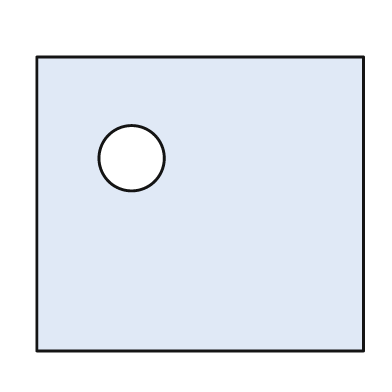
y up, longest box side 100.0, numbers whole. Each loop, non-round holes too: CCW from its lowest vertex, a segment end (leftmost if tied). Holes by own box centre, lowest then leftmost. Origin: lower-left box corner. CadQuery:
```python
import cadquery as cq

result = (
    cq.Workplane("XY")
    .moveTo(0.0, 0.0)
    .lineTo(100.0, 0.0)
    .lineTo(100.0, 90.0)
    .lineTo(0.0, 90.0)
    .close()
    .moveTo(29.0, 59.0)
    .circle(10.0)
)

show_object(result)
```